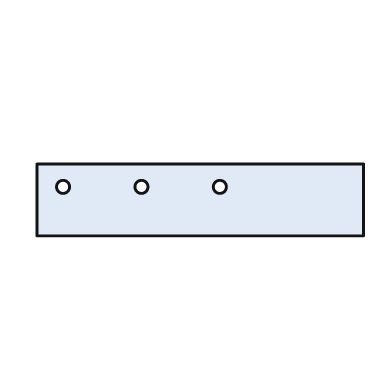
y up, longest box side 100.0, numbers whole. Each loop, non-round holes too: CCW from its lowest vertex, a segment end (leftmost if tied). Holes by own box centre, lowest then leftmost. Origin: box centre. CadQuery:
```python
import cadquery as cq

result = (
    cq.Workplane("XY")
    .moveTo(-50.0, -11.0)
    .lineTo(50.0, -11.0)
    .lineTo(50.0, 11.0)
    .lineTo(-50.0, 11.0)
    .close()
    .moveTo(-42.0, 4.0)
    .circle(2.0)
    .moveTo(-18.0, 4.0)
    .circle(2.0)
    .moveTo(6.0, 4.0)
    .circle(2.0)
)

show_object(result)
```